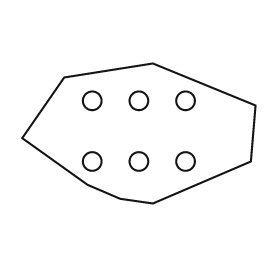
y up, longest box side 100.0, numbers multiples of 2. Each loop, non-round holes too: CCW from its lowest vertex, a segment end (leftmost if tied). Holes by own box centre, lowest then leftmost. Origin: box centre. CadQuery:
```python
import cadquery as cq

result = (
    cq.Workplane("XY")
    .moveTo(6.0, -30.0)
    .lineTo(48.0, -12.0)
    .lineTo(50.0, 12.0)
    .lineTo(6.0, 30.0)
    .lineTo(-32.0, 24.0)
    .lineTo(-50.0, -2.0)
    .lineTo(-22.0, -22.0)
    .lineTo(-8.0, -28.0)
    .close()
    .moveTo(-20.0, -12.0)
    .circle(4.0)
    .moveTo(0.0, -12.0)
    .circle(4.0)
    .moveTo(20.0, -12.0)
    .circle(4.0)
    .moveTo(-20.0, 14.0)
    .circle(4.0)
    .moveTo(0.0, 14.0)
    .circle(4.0)
    .moveTo(20.0, 14.0)
    .circle(4.0)
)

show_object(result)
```